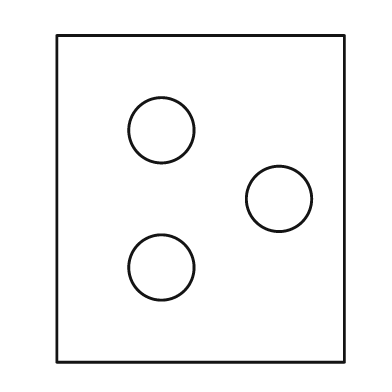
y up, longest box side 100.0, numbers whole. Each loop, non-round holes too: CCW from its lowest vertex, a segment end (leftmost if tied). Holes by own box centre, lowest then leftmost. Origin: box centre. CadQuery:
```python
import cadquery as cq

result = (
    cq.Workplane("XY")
    .moveTo(-44.0, -50.0)
    .lineTo(44.0, -50.0)
    .lineTo(44.0, 50.0)
    .lineTo(-44.0, 50.0)
    .close()
    .moveTo(-12.0, -21.0)
    .circle(10.0)
    .moveTo(24.0, 0.0)
    .circle(10.0)
    .moveTo(-12.0, 21.0)
    .circle(10.0)
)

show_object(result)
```